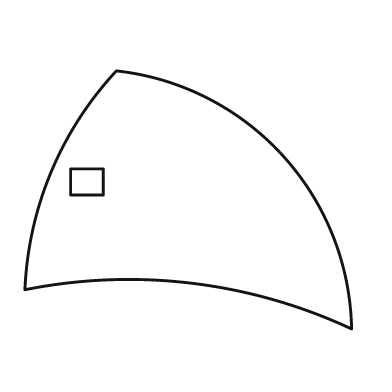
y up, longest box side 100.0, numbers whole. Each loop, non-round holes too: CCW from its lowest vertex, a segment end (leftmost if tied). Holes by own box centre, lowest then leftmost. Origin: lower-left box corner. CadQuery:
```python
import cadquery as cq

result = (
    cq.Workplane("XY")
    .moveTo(100.0, 0.0)
    .threePointArc((79.0, 53.0), (28.0, 79.0))
    .threePointArc((8.0, 48.0), (0.0, 12.0))
    .threePointArc((51.0, 14.0), (100.0, 0.0))
    .close()
    .moveTo(14.0, 41.0)
    .lineTo(24.0, 41.0)
    .lineTo(24.0, 49.0)
    .lineTo(14.0, 49.0)
    .close()
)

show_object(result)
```